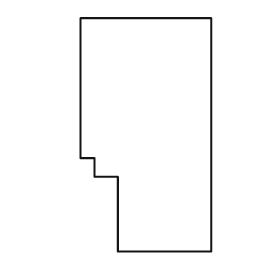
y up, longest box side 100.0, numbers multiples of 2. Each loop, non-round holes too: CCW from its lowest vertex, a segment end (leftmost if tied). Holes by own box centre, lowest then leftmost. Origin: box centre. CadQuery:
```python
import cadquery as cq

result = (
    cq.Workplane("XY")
    .moveTo(-12.0, -50.0)
    .lineTo(28.0, -50.0)
    .lineTo(28.0, 50.0)
    .lineTo(-28.0, 50.0)
    .lineTo(-28.0, -10.0)
    .lineTo(-22.0, -10.0)
    .lineTo(-22.0, -18.0)
    .lineTo(-12.0, -18.0)
    .close()
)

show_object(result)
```